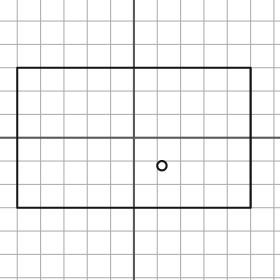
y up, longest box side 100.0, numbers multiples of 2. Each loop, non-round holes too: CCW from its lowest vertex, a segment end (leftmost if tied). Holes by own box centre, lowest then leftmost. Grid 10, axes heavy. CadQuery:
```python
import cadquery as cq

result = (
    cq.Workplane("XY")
    .moveTo(-50.0, -30.0)
    .lineTo(50.0, -30.0)
    .lineTo(50.0, 30.0)
    .lineTo(-50.0, 30.0)
    .close()
    .moveTo(12.0, -12.0)
    .circle(2.0)
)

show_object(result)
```